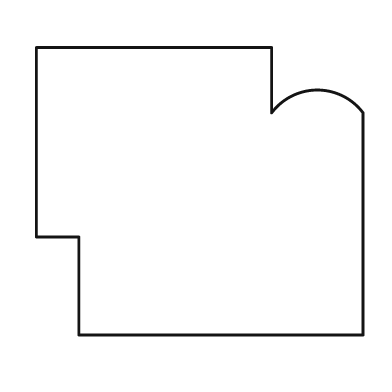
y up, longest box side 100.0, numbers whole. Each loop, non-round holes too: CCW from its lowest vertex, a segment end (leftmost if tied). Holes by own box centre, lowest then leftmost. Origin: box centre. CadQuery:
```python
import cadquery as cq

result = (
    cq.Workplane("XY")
    .moveTo(-37.0, -44.0)
    .lineTo(50.0, -44.0)
    .lineTo(50.0, 24.0)
    .threePointArc((36.0, 31.0), (22.0, 24.0))
    .lineTo(22.0, 44.0)
    .lineTo(-50.0, 44.0)
    .lineTo(-50.0, -14.0)
    .lineTo(-37.0, -14.0)
    .close()
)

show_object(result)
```